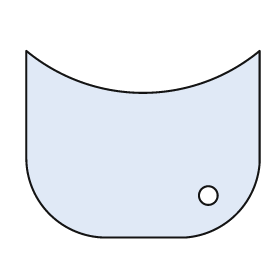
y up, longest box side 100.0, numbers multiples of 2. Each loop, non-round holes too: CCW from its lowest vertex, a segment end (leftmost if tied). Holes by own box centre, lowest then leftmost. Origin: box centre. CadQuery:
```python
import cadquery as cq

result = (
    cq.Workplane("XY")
    .moveTo(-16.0, -40.0)
    .lineTo(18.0, -40.0)
    .threePointArc((40.0, -30.0), (50.0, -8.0))
    .lineTo(50.0, 40.0)
    .threePointArc((0.0, 22.0), (-50.0, 40.0))
    .lineTo(-50.0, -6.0)
    .threePointArc((-40.0, -30.0), (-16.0, -40.0))
    .close()
    .moveTo(28.0, -22.0)
    .circle(4.0)
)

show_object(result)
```